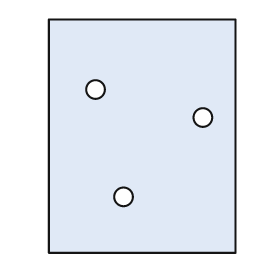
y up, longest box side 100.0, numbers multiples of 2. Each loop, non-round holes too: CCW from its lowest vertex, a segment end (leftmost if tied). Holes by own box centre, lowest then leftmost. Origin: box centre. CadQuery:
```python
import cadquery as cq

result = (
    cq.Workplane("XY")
    .moveTo(-40.0, -50.0)
    .lineTo(40.0, -50.0)
    .lineTo(40.0, 50.0)
    .lineTo(-40.0, 50.0)
    .close()
    .moveTo(-8.0, -26.0)
    .circle(4.0)
    .moveTo(26.0, 8.0)
    .circle(4.0)
    .moveTo(-20.0, 20.0)
    .circle(4.0)
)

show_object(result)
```